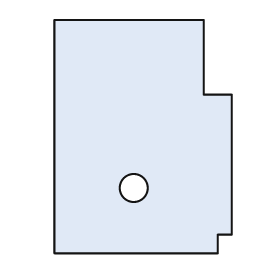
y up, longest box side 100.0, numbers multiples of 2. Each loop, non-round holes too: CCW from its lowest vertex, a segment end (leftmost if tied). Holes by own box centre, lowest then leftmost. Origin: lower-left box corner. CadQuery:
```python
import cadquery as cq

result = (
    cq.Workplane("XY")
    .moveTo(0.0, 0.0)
    .lineTo(70.0, 0.0)
    .lineTo(70.0, 8.0)
    .lineTo(76.0, 8.0)
    .lineTo(76.0, 68.0)
    .lineTo(64.0, 68.0)
    .lineTo(64.0, 100.0)
    .lineTo(0.0, 100.0)
    .close()
    .moveTo(34.0, 28.0)
    .circle(6.0)
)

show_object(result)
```